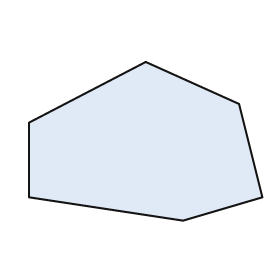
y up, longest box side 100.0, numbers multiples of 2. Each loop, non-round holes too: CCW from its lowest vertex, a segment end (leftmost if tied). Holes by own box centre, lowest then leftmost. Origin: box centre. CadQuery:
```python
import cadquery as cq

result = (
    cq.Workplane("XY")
    .moveTo(16.0, -34.0)
    .lineTo(50.0, -24.0)
    .lineTo(40.0, 16.0)
    .lineTo(0.0, 34.0)
    .lineTo(-50.0, 8.0)
    .lineTo(-50.0, -24.0)
    .close()
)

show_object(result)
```